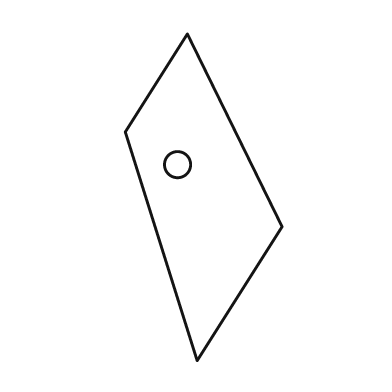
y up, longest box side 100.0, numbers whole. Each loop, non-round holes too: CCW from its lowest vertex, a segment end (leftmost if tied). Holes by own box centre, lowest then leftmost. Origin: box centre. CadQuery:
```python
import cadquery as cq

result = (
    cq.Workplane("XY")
    .moveTo(-2.0, -50.0)
    .lineTo(24.0, -9.0)
    .lineTo(-5.0, 50.0)
    .lineTo(-24.0, 20.0)
    .close()
    .moveTo(-8.0, 10.0)
    .circle(4.0)
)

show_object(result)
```